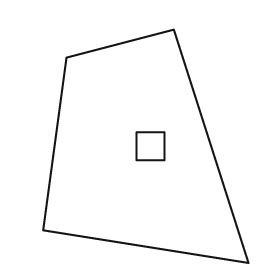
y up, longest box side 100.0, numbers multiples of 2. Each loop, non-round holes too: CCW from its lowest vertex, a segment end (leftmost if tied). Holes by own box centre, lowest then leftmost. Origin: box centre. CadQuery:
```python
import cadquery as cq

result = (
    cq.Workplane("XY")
    .moveTo(44.0, -50.0)
    .lineTo(12.0, 50.0)
    .lineTo(-34.0, 38.0)
    .lineTo(-44.0, -36.0)
    .close()
    .moveTo(-4.0, -6.0)
    .lineTo(8.0, -6.0)
    .lineTo(8.0, 6.0)
    .lineTo(-4.0, 6.0)
    .close()
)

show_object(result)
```